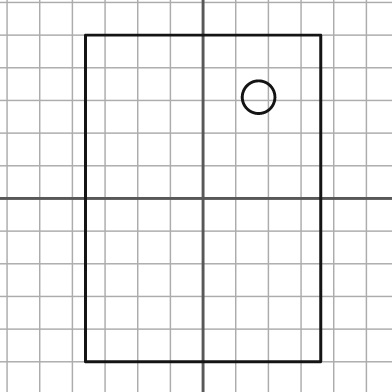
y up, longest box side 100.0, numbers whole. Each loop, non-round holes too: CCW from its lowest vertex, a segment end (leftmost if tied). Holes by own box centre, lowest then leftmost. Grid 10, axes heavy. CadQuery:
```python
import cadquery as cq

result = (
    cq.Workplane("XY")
    .moveTo(-36.0, -50.0)
    .lineTo(36.0, -50.0)
    .lineTo(36.0, 50.0)
    .lineTo(-36.0, 50.0)
    .close()
    .moveTo(17.0, 31.0)
    .circle(5.0)
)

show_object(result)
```